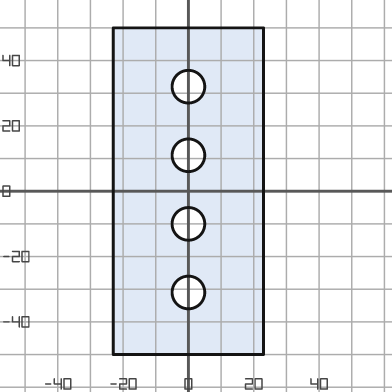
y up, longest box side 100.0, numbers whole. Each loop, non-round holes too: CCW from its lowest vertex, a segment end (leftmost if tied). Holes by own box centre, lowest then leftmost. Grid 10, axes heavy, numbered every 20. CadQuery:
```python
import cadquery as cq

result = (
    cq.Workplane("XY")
    .moveTo(-23.0, -50.0)
    .lineTo(23.0, -50.0)
    .lineTo(23.0, 50.0)
    .lineTo(-23.0, 50.0)
    .close()
    .moveTo(0.0, -31.0)
    .circle(5.0)
    .moveTo(0.0, -10.0)
    .circle(5.0)
    .moveTo(0.0, 11.0)
    .circle(5.0)
    .moveTo(0.0, 32.0)
    .circle(5.0)
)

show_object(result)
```